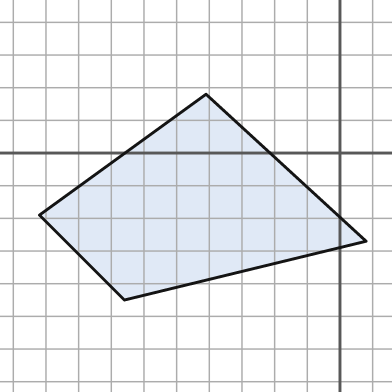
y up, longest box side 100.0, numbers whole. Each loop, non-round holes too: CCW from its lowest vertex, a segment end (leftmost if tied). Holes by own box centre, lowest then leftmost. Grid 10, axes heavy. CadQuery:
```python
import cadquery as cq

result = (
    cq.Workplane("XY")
    .moveTo(-66.0, -45.0)
    .lineTo(8.0, -27.0)
    .lineTo(-41.0, 18.0)
    .lineTo(-92.0, -19.0)
    .close()
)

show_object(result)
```